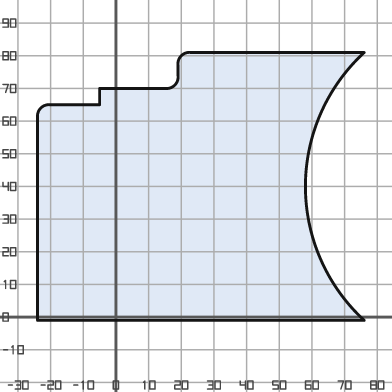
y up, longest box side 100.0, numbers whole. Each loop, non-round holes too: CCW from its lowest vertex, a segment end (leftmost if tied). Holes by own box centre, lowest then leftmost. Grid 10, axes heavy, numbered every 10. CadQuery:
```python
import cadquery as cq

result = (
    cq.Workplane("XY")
    .moveTo(-24.0, -1.0)
    .lineTo(76.0, -1.0)
    .threePointArc((58.0, 40.0), (76.0, 81.0))
    .lineTo(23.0, 81.0)
    .threePointArc((20.0, 80.0), (19.0, 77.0))
    .lineTo(19.0, 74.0)
    .threePointArc((18.0, 71.0), (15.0, 70.0))
    .lineTo(-5.0, 70.0)
    .lineTo(-5.0, 65.0)
    .lineTo(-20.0, 65.0)
    .threePointArc((-23.0, 64.0), (-24.0, 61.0))
    .close()
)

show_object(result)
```